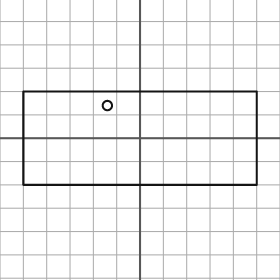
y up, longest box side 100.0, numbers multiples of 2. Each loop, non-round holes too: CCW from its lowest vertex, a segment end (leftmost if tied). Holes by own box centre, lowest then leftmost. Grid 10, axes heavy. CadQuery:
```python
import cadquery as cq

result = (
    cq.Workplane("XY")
    .moveTo(-50.0, -20.0)
    .lineTo(50.0, -20.0)
    .lineTo(50.0, 20.0)
    .lineTo(-50.0, 20.0)
    .close()
    .moveTo(-14.0, 14.0)
    .circle(2.0)
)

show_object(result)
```